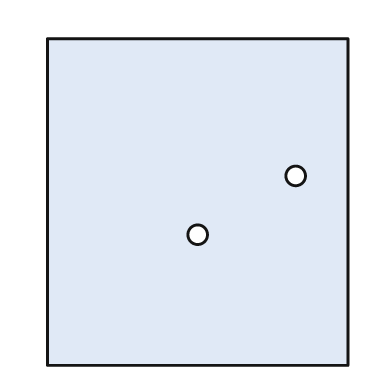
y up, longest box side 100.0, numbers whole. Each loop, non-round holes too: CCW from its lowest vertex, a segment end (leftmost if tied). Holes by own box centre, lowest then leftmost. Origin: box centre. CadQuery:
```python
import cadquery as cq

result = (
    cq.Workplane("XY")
    .moveTo(-46.0, -50.0)
    .lineTo(46.0, -50.0)
    .lineTo(46.0, 50.0)
    .lineTo(-46.0, 50.0)
    .close()
    .moveTo(0.0, -10.0)
    .circle(3.0)
    .moveTo(30.0, 8.0)
    .circle(3.0)
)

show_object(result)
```